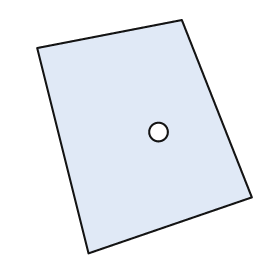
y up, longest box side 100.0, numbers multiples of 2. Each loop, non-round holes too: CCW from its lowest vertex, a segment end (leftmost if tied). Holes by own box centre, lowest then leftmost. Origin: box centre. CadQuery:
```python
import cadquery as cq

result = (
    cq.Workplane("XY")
    .moveTo(-24.0, -50.0)
    .lineTo(46.0, -26.0)
    .lineTo(16.0, 50.0)
    .lineTo(-46.0, 38.0)
    .close()
    .moveTo(6.0, 2.0)
    .circle(4.0)
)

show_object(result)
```